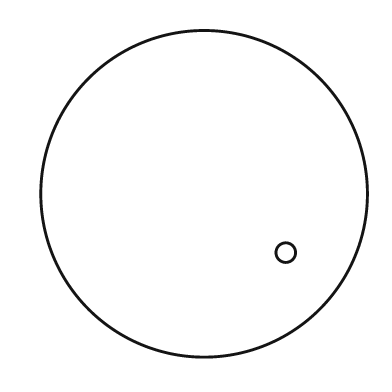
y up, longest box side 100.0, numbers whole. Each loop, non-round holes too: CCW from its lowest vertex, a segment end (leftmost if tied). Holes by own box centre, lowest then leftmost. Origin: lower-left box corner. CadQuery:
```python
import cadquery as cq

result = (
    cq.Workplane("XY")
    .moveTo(50.0, 50.0)
    .circle(50.0)
    .moveTo(75.0, 32.0)
    .circle(3.0)
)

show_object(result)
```